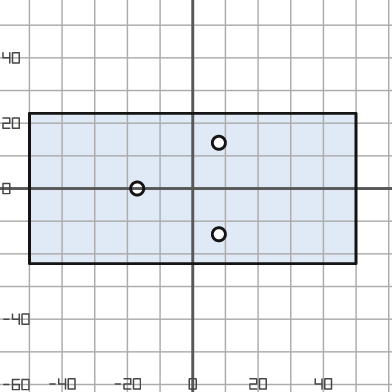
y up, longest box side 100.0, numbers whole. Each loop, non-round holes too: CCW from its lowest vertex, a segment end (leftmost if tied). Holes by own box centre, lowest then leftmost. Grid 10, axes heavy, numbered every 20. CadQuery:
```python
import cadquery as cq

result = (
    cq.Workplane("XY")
    .moveTo(-50.0, -23.0)
    .lineTo(50.0, -23.0)
    .lineTo(50.0, 23.0)
    .lineTo(-50.0, 23.0)
    .close()
    .moveTo(8.0, -14.0)
    .circle(2.0)
    .moveTo(-17.0, 0.0)
    .circle(2.0)
    .moveTo(8.0, 14.0)
    .circle(2.0)
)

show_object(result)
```